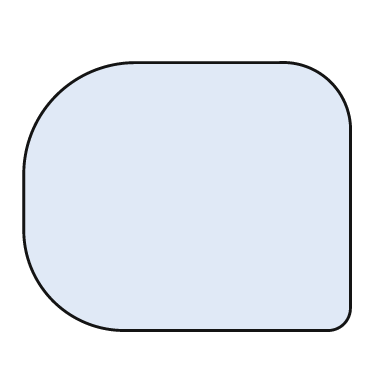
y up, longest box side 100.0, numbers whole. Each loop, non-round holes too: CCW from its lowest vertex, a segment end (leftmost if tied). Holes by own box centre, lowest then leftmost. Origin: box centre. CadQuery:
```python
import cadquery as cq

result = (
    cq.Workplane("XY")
    .moveTo(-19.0, -41.0)
    .lineTo(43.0, -41.0)
    .threePointArc((48.0, -39.0), (50.0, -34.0))
    .lineTo(50.0, 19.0)
    .threePointArc((44.0, 35.0), (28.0, 41.0))
    .lineTo(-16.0, 41.0)
    .threePointArc((-40.0, 31.0), (-50.0, 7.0))
    .lineTo(-50.0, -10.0)
    .threePointArc((-41.0, -32.0), (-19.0, -41.0))
    .close()
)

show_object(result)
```